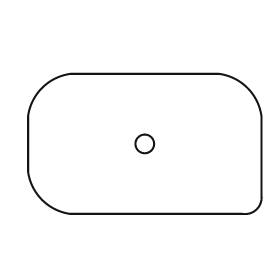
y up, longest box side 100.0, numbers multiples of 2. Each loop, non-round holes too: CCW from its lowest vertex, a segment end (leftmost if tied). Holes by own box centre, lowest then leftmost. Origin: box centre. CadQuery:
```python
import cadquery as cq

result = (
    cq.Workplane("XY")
    .moveTo(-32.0, -30.0)
    .lineTo(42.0, -30.0)
    .threePointArc((48.0, -28.0), (50.0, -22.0))
    .lineTo(50.0, 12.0)
    .threePointArc((44.0, 24.0), (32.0, 30.0))
    .lineTo(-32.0, 30.0)
    .threePointArc((-44.0, 24.0), (-50.0, 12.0))
    .lineTo(-50.0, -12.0)
    .threePointArc((-44.0, -24.0), (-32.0, -30.0))
    .close()
    .moveTo(0.0, 0.0)
    .circle(4.0)
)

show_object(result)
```